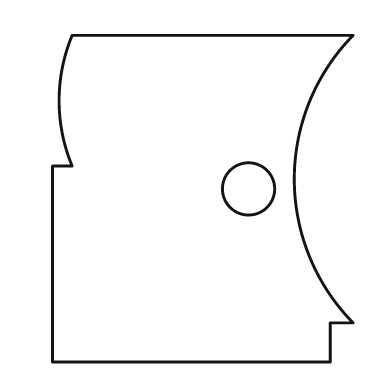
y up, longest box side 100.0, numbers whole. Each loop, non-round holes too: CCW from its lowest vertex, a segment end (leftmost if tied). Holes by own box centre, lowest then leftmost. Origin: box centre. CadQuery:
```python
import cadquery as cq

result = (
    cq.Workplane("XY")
    .moveTo(-46.0, -50.0)
    .lineTo(39.0, -50.0)
    .lineTo(39.0, -38.0)
    .lineTo(46.0, -38.0)
    .threePointArc((28.0, 6.0), (46.0, 50.0))
    .lineTo(-40.0, 50.0)
    .threePointArc((-44.0, 30.0), (-40.0, 10.0))
    .lineTo(-46.0, 10.0)
    .close()
    .moveTo(14.0, 3.0)
    .circle(8.0)
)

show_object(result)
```